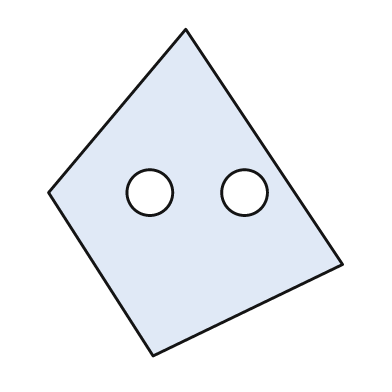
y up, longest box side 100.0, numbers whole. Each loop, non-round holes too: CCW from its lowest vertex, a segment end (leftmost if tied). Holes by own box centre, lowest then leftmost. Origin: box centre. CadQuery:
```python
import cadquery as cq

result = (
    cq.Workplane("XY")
    .moveTo(-13.0, -50.0)
    .lineTo(45.0, -22.0)
    .lineTo(-3.0, 50.0)
    .lineTo(-45.0, 0.0)
    .close()
    .moveTo(-14.0, 0.0)
    .circle(7.0)
    .moveTo(15.0, 0.0)
    .circle(7.0)
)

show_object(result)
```